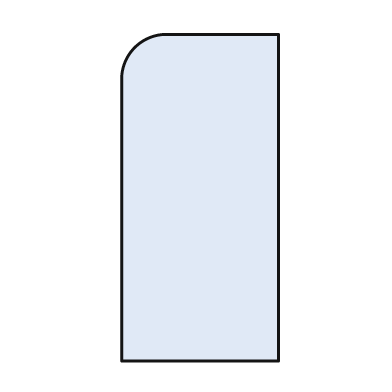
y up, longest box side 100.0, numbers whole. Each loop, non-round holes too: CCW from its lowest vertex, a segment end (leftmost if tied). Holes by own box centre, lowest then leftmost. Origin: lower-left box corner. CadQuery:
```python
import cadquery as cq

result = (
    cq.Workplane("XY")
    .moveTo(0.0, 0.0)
    .lineTo(48.0, 0.0)
    .lineTo(48.0, 100.0)
    .lineTo(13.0, 100.0)
    .threePointArc((4.0, 96.0), (0.0, 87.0))
    .close()
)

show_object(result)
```